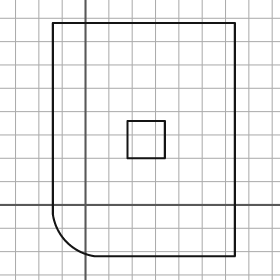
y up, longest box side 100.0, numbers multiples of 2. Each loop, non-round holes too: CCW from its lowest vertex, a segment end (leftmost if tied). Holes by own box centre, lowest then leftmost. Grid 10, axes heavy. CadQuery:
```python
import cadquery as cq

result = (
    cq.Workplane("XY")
    .moveTo(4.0, -22.0)
    .lineTo(64.0, -22.0)
    .lineTo(64.0, 78.0)
    .lineTo(-14.0, 78.0)
    .lineTo(-14.0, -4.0)
    .threePointArc((-8.0, -16.0), (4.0, -22.0))
    .close()
    .moveTo(18.0, 20.0)
    .lineTo(34.0, 20.0)
    .lineTo(34.0, 36.0)
    .lineTo(18.0, 36.0)
    .close()
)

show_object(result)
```